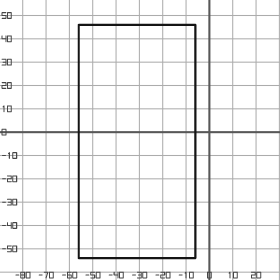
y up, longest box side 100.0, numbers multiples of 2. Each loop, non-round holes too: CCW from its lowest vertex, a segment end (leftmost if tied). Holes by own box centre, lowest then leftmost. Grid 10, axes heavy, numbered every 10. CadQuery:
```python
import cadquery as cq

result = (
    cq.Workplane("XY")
    .moveTo(-56.0, -54.0)
    .lineTo(-6.0, -54.0)
    .lineTo(-6.0, 46.0)
    .lineTo(-56.0, 46.0)
    .close()
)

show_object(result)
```